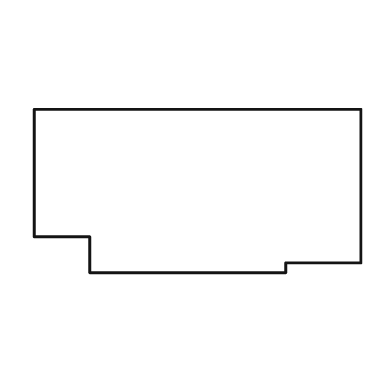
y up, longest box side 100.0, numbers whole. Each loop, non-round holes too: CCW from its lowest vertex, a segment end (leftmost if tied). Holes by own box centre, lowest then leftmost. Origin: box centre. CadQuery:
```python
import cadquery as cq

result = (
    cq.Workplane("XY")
    .moveTo(-33.0, -25.0)
    .lineTo(27.0, -25.0)
    .lineTo(27.0, -22.0)
    .lineTo(50.0, -22.0)
    .lineTo(50.0, 25.0)
    .lineTo(-50.0, 25.0)
    .lineTo(-50.0, -14.0)
    .lineTo(-33.0, -14.0)
    .close()
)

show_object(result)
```